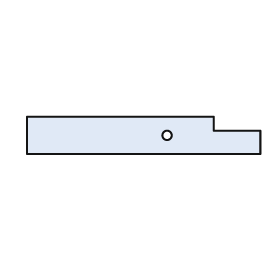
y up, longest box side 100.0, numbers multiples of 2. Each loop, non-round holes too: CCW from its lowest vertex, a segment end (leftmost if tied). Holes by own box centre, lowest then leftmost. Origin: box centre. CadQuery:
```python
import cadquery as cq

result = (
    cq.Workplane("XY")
    .moveTo(-50.0, -8.0)
    .lineTo(50.0, -8.0)
    .lineTo(50.0, 2.0)
    .lineTo(30.0, 2.0)
    .lineTo(30.0, 8.0)
    .lineTo(-50.0, 8.0)
    .close()
    .moveTo(10.0, 0.0)
    .circle(2.0)
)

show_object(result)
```